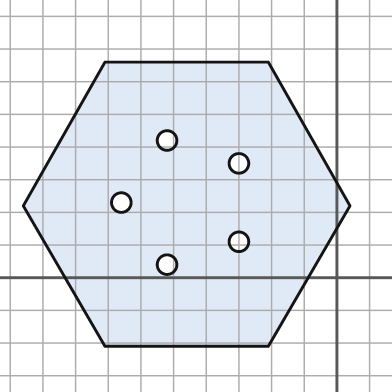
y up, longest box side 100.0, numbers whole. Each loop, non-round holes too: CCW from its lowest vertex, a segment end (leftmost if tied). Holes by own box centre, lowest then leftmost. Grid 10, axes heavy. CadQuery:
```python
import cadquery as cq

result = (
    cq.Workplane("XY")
    .moveTo(-71.0, -21.0)
    .lineTo(-21.0, -21.0)
    .lineTo(4.0, 22.0)
    .lineTo(-21.0, 66.0)
    .lineTo(-71.0, 66.0)
    .lineTo(-96.0, 22.0)
    .close()
    .moveTo(-52.0, 4.0)
    .circle(3.0)
    .moveTo(-30.0, 11.0)
    .circle(3.0)
    .moveTo(-66.0, 23.0)
    .circle(3.0)
    .moveTo(-30.0, 35.0)
    .circle(3.0)
    .moveTo(-52.0, 42.0)
    .circle(3.0)
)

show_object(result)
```